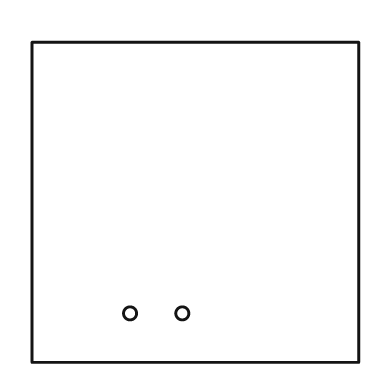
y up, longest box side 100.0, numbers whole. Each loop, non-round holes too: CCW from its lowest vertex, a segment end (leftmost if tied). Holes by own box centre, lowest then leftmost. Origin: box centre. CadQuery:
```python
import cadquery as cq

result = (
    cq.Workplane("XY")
    .moveTo(-50.0, -49.0)
    .lineTo(50.0, -49.0)
    .lineTo(50.0, 49.0)
    .lineTo(-50.0, 49.0)
    .close()
    .moveTo(-20.0, -34.0)
    .circle(2.0)
    .moveTo(-4.0, -34.0)
    .circle(2.0)
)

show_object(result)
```